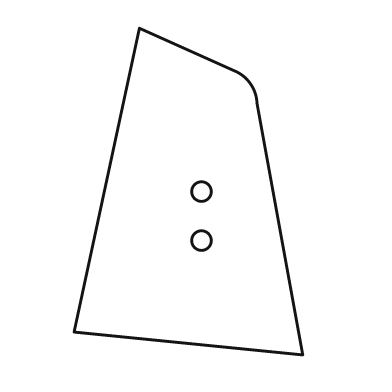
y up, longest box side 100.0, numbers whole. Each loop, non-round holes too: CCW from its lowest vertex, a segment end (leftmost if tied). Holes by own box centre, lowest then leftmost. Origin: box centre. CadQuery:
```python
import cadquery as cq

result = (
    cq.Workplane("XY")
    .moveTo(35.0, -50.0)
    .lineTo(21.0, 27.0)
    .threePointArc((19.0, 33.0), (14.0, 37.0))
    .lineTo(-15.0, 50.0)
    .lineTo(-35.0, -43.0)
    .close()
    .moveTo(4.0, -15.0)
    .circle(3.0)
    .moveTo(4.0, 0.0)
    .circle(3.0)
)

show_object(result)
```